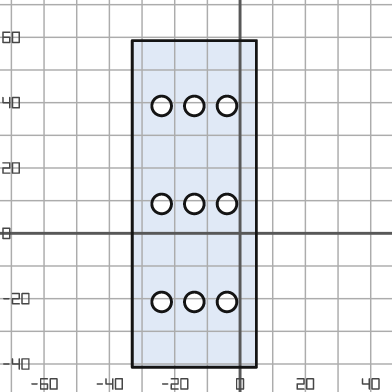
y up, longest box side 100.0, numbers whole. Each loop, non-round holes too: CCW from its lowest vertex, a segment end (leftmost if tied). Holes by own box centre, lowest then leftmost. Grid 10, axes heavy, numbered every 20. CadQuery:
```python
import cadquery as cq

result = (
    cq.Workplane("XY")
    .moveTo(-33.0, -41.0)
    .lineTo(5.0, -41.0)
    .lineTo(5.0, 59.0)
    .lineTo(-33.0, 59.0)
    .close()
    .moveTo(-24.0, -21.0)
    .circle(3.0)
    .moveTo(-14.0, -21.0)
    .circle(3.0)
    .moveTo(-4.0, -21.0)
    .circle(3.0)
    .moveTo(-24.0, 9.0)
    .circle(3.0)
    .moveTo(-14.0, 9.0)
    .circle(3.0)
    .moveTo(-4.0, 9.0)
    .circle(3.0)
    .moveTo(-24.0, 39.0)
    .circle(3.0)
    .moveTo(-14.0, 39.0)
    .circle(3.0)
    .moveTo(-4.0, 39.0)
    .circle(3.0)
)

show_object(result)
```